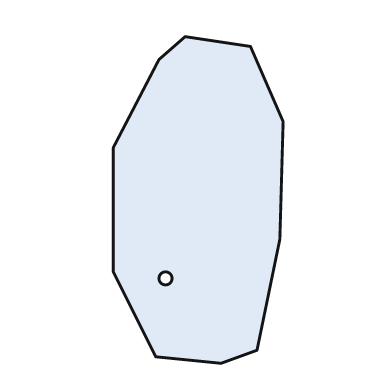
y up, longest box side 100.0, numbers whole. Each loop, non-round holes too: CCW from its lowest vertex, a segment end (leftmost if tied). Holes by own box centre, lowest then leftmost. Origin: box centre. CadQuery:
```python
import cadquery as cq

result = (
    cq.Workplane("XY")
    .moveTo(7.0, -50.0)
    .lineTo(18.0, -46.0)
    .lineTo(25.0, -12.0)
    .lineTo(26.0, 24.0)
    .lineTo(16.0, 47.0)
    .lineTo(-4.0, 50.0)
    .lineTo(-12.0, 43.0)
    .lineTo(-26.0, 16.0)
    .lineTo(-26.0, -22.0)
    .lineTo(-13.0, -48.0)
    .close()
    .moveTo(-10.0, -24.0)
    .circle(2.0)
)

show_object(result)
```